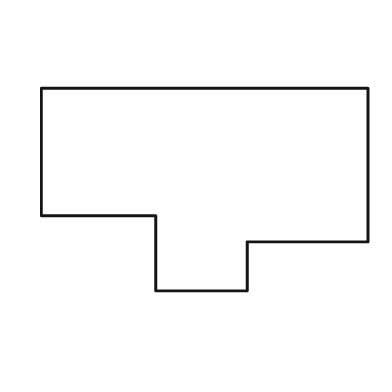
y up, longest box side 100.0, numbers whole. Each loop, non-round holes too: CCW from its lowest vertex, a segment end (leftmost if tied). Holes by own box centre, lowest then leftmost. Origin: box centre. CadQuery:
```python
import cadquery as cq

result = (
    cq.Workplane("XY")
    .moveTo(-15.0, -31.0)
    .lineTo(13.0, -31.0)
    .lineTo(13.0, -16.0)
    .lineTo(50.0, -16.0)
    .lineTo(50.0, 31.0)
    .lineTo(-50.0, 31.0)
    .lineTo(-50.0, -8.0)
    .lineTo(-15.0, -8.0)
    .close()
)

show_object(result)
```